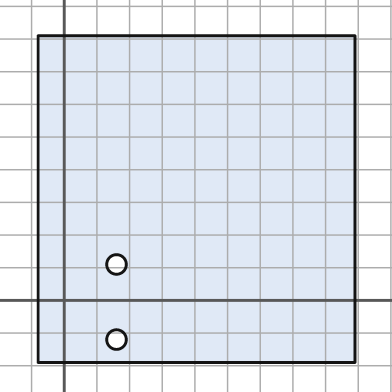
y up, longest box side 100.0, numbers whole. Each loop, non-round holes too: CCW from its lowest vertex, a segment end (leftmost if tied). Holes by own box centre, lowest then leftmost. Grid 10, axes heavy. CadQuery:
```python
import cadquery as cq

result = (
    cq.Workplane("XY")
    .moveTo(-8.0, -19.0)
    .lineTo(89.0, -19.0)
    .lineTo(89.0, 81.0)
    .lineTo(-8.0, 81.0)
    .close()
    .moveTo(16.0, -12.0)
    .circle(3.0)
    .moveTo(16.0, 11.0)
    .circle(3.0)
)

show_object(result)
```